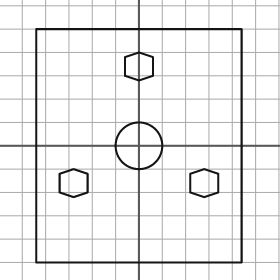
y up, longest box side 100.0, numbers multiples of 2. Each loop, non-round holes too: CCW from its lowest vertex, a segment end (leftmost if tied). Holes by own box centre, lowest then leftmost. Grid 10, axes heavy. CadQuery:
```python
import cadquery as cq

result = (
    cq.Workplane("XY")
    .moveTo(-44.0, -50.0)
    .lineTo(44.0, -50.0)
    .lineTo(44.0, 50.0)
    .lineTo(-44.0, 50.0)
    .close()
    .moveTo(-28.0, -22.0)
    .lineTo(-22.0, -20.0)
    .lineTo(-22.0, -12.0)
    .lineTo(-28.0, -10.0)
    .lineTo(-34.0, -12.0)
    .lineTo(-34.0, -20.0)
    .close()
    .moveTo(28.0, -22.0)
    .lineTo(34.0, -20.0)
    .lineTo(34.0, -12.0)
    .lineTo(28.0, -10.0)
    .lineTo(22.0, -12.0)
    .lineTo(22.0, -20.0)
    .close()
    .moveTo(0.0, 0.0)
    .circle(10.0)
    .moveTo(0.0, 28.0)
    .lineTo(6.0, 30.0)
    .lineTo(6.0, 38.0)
    .lineTo(0.0, 40.0)
    .lineTo(-6.0, 38.0)
    .lineTo(-6.0, 30.0)
    .close()
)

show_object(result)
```